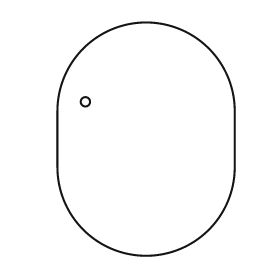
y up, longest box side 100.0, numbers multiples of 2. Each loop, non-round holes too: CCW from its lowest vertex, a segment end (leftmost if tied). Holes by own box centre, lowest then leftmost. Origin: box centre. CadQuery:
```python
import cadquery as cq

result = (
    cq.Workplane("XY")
    .moveTo(-38.0, -12.0)
    .threePointArc((0.0, -50.0), (38.0, -12.0))
    .lineTo(38.0, 12.0)
    .threePointArc((0.0, 50.0), (-38.0, 12.0))
    .close()
    .moveTo(-26.0, 16.0)
    .circle(2.0)
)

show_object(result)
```